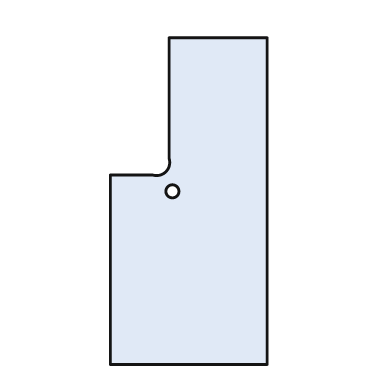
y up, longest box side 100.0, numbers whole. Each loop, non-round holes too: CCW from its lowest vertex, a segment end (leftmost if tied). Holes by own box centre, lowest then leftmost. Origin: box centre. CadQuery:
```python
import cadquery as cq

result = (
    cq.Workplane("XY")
    .moveTo(-24.0, -50.0)
    .lineTo(24.0, -50.0)
    .lineTo(24.0, 50.0)
    .lineTo(-6.0, 50.0)
    .lineTo(-6.0, 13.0)
    .threePointArc((-7.0, 9.0), (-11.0, 8.0))
    .lineTo(-24.0, 8.0)
    .close()
    .moveTo(-5.0, 3.0)
    .circle(2.0)
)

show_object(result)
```